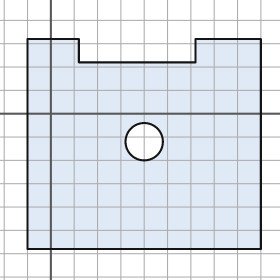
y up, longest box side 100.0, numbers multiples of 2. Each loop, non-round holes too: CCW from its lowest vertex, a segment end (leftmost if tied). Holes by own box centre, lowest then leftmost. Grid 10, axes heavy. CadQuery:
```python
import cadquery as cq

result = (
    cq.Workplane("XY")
    .moveTo(-10.0, -58.0)
    .lineTo(90.0, -58.0)
    .lineTo(90.0, 32.0)
    .lineTo(62.0, 32.0)
    .lineTo(62.0, 22.0)
    .lineTo(12.0, 22.0)
    .lineTo(12.0, 32.0)
    .lineTo(-10.0, 32.0)
    .close()
    .moveTo(40.0, -12.0)
    .circle(8.0)
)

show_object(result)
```